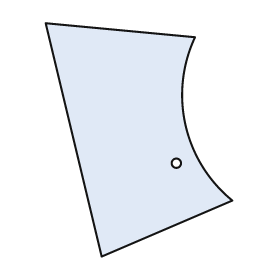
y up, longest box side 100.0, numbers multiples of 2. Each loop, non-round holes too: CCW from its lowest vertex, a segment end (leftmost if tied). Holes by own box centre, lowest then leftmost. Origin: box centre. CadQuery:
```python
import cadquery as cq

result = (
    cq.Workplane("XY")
    .moveTo(-16.0, -50.0)
    .lineTo(40.0, -26.0)
    .threePointArc((20.0, 6.0), (24.0, 44.0))
    .lineTo(-40.0, 50.0)
    .close()
    .moveTo(16.0, -10.0)
    .circle(2.0)
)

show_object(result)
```